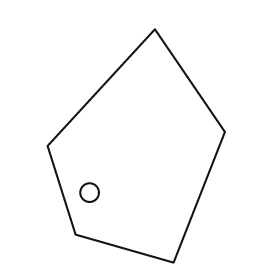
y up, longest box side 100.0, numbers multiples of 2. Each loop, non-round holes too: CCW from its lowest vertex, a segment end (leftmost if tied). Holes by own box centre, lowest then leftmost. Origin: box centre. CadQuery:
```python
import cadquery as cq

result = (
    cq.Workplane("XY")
    .moveTo(16.0, -50.0)
    .lineTo(38.0, 6.0)
    .lineTo(8.0, 50.0)
    .lineTo(-38.0, 0.0)
    .lineTo(-26.0, -38.0)
    .close()
    .moveTo(-20.0, -20.0)
    .circle(4.0)
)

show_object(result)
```